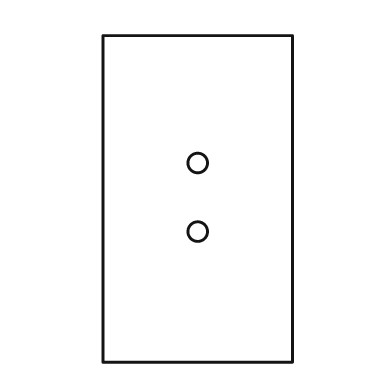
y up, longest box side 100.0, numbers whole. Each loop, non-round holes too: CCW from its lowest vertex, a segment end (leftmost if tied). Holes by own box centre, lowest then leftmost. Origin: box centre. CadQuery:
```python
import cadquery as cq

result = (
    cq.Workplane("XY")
    .moveTo(-29.0, -50.0)
    .lineTo(29.0, -50.0)
    .lineTo(29.0, 50.0)
    .lineTo(-29.0, 50.0)
    .close()
    .moveTo(0.0, -10.0)
    .circle(3.0)
    .moveTo(0.0, 11.0)
    .circle(3.0)
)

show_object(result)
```